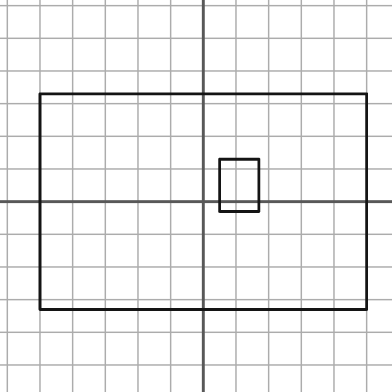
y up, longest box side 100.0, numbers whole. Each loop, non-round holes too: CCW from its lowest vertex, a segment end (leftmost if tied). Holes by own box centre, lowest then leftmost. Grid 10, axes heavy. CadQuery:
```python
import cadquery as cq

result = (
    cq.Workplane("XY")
    .moveTo(-50.0, -33.0)
    .lineTo(50.0, -33.0)
    .lineTo(50.0, 33.0)
    .lineTo(-50.0, 33.0)
    .close()
    .moveTo(5.0, -3.0)
    .lineTo(17.0, -3.0)
    .lineTo(17.0, 13.0)
    .lineTo(5.0, 13.0)
    .close()
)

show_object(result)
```